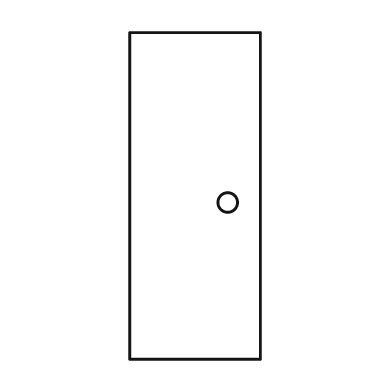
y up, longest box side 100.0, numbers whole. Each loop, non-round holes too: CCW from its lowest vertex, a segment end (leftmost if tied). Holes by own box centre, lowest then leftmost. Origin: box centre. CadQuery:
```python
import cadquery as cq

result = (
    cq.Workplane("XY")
    .moveTo(-20.0, -50.0)
    .lineTo(20.0, -50.0)
    .lineTo(20.0, 50.0)
    .lineTo(-20.0, 50.0)
    .close()
    .moveTo(10.0, -2.0)
    .circle(3.0)
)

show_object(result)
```